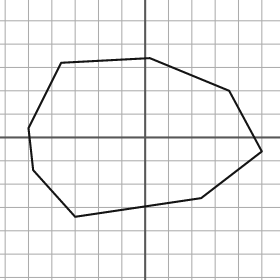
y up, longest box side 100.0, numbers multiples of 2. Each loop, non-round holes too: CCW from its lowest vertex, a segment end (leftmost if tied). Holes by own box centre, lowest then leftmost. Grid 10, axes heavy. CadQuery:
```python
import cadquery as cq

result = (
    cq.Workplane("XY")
    .moveTo(-30.0, -34.0)
    .lineTo(24.0, -26.0)
    .lineTo(50.0, -6.0)
    .lineTo(36.0, 20.0)
    .lineTo(2.0, 34.0)
    .lineTo(-36.0, 32.0)
    .lineTo(-50.0, 4.0)
    .lineTo(-48.0, -14.0)
    .close()
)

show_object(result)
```